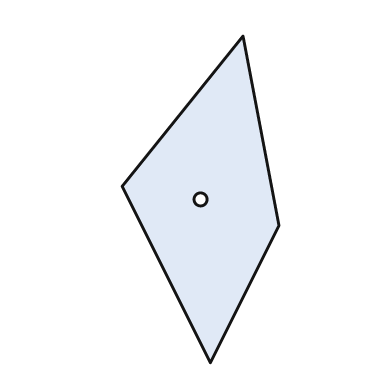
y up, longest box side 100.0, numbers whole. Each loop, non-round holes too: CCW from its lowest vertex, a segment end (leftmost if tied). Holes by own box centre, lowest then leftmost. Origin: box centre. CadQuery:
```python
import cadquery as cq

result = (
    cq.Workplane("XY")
    .moveTo(3.0, -50.0)
    .lineTo(24.0, -8.0)
    .lineTo(13.0, 50.0)
    .lineTo(-24.0, 4.0)
    .close()
    .moveTo(0.0, 0.0)
    .circle(2.0)
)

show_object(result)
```